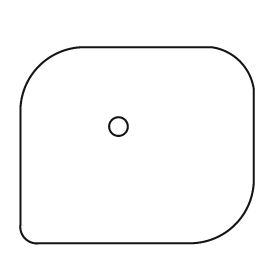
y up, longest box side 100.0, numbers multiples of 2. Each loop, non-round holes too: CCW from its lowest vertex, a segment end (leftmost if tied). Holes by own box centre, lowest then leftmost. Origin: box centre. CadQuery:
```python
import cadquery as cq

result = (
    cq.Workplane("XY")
    .moveTo(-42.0, -42.0)
    .lineTo(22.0, -42.0)
    .threePointArc((42.0, -34.0), (50.0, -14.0))
    .lineTo(50.0, 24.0)
    .threePointArc((44.0, 36.0), (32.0, 42.0))
    .lineTo(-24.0, 42.0)
    .threePointArc((-42.0, 34.0), (-50.0, 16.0))
    .lineTo(-50.0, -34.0)
    .threePointArc((-48.0, -40.0), (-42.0, -42.0))
    .close()
    .moveTo(-8.0, 8.0)
    .circle(4.0)
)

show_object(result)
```